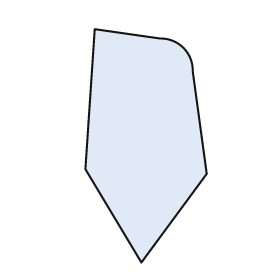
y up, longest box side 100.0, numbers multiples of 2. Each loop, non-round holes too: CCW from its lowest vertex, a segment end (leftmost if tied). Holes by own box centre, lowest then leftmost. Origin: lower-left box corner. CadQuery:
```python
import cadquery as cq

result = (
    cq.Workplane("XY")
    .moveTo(24.0, 0.0)
    .lineTo(52.0, 38.0)
    .lineTo(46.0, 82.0)
    .threePointArc((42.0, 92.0), (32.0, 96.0))
    .lineTo(4.0, 100.0)
    .lineTo(0.0, 40.0)
    .close()
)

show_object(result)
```